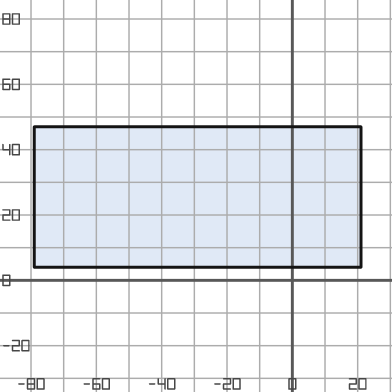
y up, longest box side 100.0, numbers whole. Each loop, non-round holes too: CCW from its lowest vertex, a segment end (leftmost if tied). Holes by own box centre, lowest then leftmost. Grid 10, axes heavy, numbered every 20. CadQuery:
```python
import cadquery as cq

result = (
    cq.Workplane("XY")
    .moveTo(-79.0, 4.0)
    .lineTo(21.0, 4.0)
    .lineTo(21.0, 47.0)
    .lineTo(-79.0, 47.0)
    .close()
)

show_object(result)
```